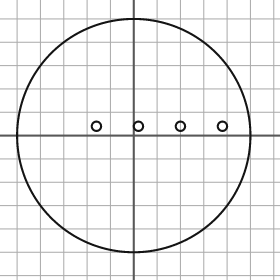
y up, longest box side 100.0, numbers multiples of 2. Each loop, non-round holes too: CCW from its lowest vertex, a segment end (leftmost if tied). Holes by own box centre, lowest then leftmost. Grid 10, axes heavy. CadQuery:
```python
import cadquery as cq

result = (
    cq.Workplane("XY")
    .moveTo(0.0, 0.0)
    .circle(50.0)
    .moveTo(-16.0, 4.0)
    .circle(2.0)
    .moveTo(2.0, 4.0)
    .circle(2.0)
    .moveTo(20.0, 4.0)
    .circle(2.0)
    .moveTo(38.0, 4.0)
    .circle(2.0)
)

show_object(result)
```